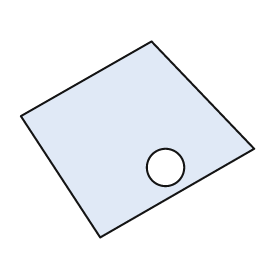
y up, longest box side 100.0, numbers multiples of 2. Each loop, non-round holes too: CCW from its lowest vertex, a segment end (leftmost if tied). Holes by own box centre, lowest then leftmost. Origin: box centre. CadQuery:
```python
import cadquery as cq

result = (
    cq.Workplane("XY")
    .moveTo(-16.0, -42.0)
    .lineTo(50.0, -4.0)
    .lineTo(6.0, 42.0)
    .lineTo(-50.0, 10.0)
    .close()
    .moveTo(12.0, -12.0)
    .circle(8.0)
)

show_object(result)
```